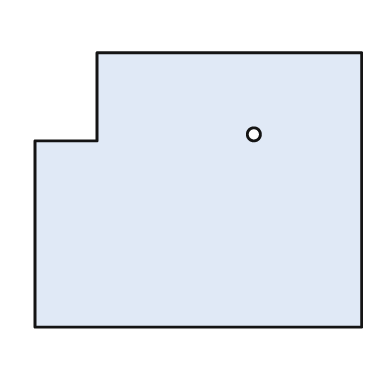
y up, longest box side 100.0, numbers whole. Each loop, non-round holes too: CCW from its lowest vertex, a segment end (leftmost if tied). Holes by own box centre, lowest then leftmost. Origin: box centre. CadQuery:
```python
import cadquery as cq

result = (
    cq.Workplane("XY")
    .moveTo(-50.0, -42.0)
    .lineTo(50.0, -42.0)
    .lineTo(50.0, 42.0)
    .lineTo(-31.0, 42.0)
    .lineTo(-31.0, 15.0)
    .lineTo(-50.0, 15.0)
    .close()
    .moveTo(17.0, 17.0)
    .circle(2.0)
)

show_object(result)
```